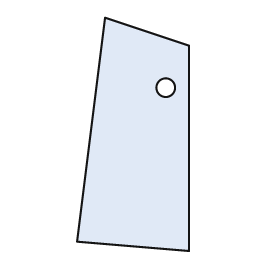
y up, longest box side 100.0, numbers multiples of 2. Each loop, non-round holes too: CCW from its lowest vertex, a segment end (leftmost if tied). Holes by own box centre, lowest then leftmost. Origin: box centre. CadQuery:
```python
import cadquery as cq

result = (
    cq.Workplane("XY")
    .moveTo(24.0, -50.0)
    .lineTo(24.0, 38.0)
    .lineTo(-12.0, 50.0)
    .lineTo(-24.0, -46.0)
    .close()
    .moveTo(14.0, 20.0)
    .circle(4.0)
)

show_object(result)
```